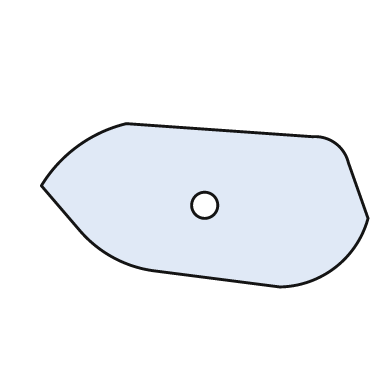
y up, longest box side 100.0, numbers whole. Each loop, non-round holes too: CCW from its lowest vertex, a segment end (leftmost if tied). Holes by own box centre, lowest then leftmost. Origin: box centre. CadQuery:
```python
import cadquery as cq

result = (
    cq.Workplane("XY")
    .moveTo(23.0, -25.0)
    .threePointArc((40.0, -19.0), (50.0, -4.0))
    .lineTo(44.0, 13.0)
    .threePointArc((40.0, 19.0), (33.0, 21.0))
    .lineTo(-24.0, 25.0)
    .threePointArc((-39.0, 18.0), (-50.0, 6.0))
    .lineTo(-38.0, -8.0)
    .threePointArc((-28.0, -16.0), (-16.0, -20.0))
    .close()
    .moveTo(0.0, 0.0)
    .circle(4.0)
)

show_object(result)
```